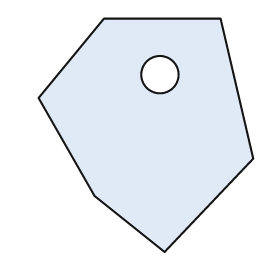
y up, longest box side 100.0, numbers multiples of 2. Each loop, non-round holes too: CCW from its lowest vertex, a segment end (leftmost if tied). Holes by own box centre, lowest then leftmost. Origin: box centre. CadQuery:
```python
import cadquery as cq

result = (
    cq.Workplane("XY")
    .moveTo(8.0, -50.0)
    .lineTo(46.0, -10.0)
    .lineTo(32.0, 50.0)
    .lineTo(-18.0, 50.0)
    .lineTo(-46.0, 16.0)
    .lineTo(-22.0, -26.0)
    .close()
    .moveTo(6.0, 26.0)
    .circle(8.0)
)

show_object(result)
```